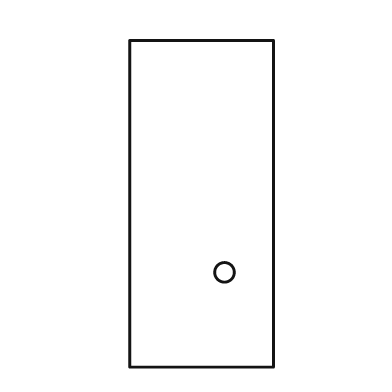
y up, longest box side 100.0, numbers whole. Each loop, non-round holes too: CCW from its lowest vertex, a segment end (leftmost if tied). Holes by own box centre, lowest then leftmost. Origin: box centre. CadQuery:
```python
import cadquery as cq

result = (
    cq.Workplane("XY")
    .moveTo(-22.0, -50.0)
    .lineTo(22.0, -50.0)
    .lineTo(22.0, 50.0)
    .lineTo(-22.0, 50.0)
    .close()
    .moveTo(7.0, -21.0)
    .circle(3.0)
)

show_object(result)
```